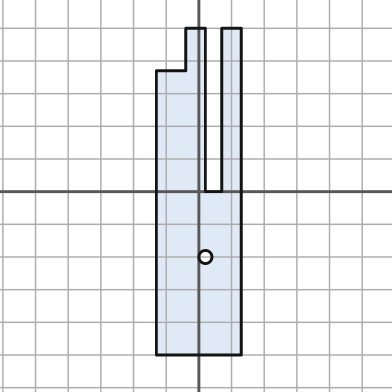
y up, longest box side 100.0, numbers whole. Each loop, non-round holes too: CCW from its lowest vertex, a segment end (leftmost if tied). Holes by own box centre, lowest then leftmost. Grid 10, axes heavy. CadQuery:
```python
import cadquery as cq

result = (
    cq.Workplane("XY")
    .moveTo(-13.0, -50.0)
    .lineTo(13.0, -50.0)
    .lineTo(13.0, 50.0)
    .lineTo(7.0, 50.0)
    .lineTo(7.0, 0.0)
    .lineTo(2.0, 0.0)
    .lineTo(2.0, 50.0)
    .lineTo(-4.0, 50.0)
    .lineTo(-4.0, 37.0)
    .lineTo(-13.0, 37.0)
    .close()
    .moveTo(2.0, -20.0)
    .circle(2.0)
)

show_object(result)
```